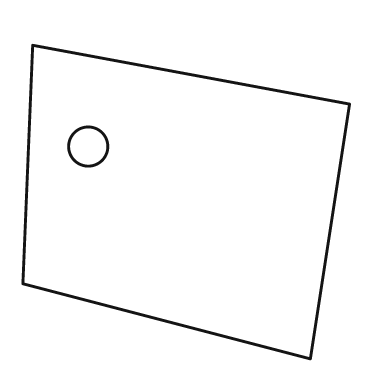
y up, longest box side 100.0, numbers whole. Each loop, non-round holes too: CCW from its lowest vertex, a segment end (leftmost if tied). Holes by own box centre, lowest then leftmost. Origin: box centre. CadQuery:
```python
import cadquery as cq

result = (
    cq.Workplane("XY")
    .moveTo(38.0, -48.0)
    .lineTo(50.0, 30.0)
    .lineTo(-47.0, 48.0)
    .lineTo(-50.0, -25.0)
    .close()
    .moveTo(-30.0, 17.0)
    .circle(6.0)
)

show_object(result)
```